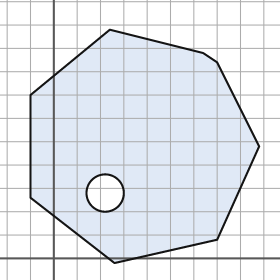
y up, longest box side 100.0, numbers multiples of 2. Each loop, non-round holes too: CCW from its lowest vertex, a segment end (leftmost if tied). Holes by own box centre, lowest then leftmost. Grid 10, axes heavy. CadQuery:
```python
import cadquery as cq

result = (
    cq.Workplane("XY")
    .moveTo(26.0, -2.0)
    .lineTo(70.0, 8.0)
    .lineTo(88.0, 48.0)
    .lineTo(70.0, 84.0)
    .lineTo(64.0, 88.0)
    .lineTo(24.0, 98.0)
    .lineTo(-10.0, 70.0)
    .lineTo(-10.0, 26.0)
    .close()
    .moveTo(22.0, 28.0)
    .circle(8.0)
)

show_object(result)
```